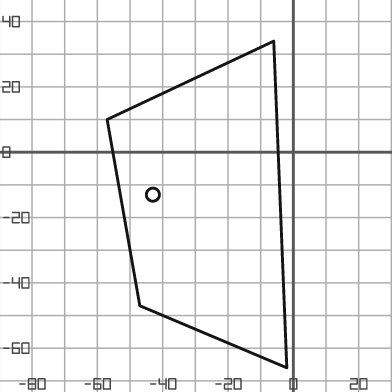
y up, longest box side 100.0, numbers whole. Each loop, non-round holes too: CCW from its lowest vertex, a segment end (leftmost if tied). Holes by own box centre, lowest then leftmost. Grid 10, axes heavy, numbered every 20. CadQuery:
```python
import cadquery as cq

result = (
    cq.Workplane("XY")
    .moveTo(-2.0, -66.0)
    .lineTo(-6.0, 34.0)
    .lineTo(-57.0, 10.0)
    .lineTo(-47.0, -47.0)
    .close()
    .moveTo(-43.0, -13.0)
    .circle(2.0)
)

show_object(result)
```